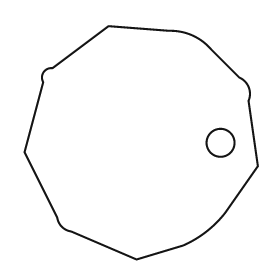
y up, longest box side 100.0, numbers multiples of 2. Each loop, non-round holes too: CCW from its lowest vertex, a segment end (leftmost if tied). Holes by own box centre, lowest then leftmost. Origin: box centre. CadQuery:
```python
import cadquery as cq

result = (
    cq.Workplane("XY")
    .moveTo(-2.0, -50.0)
    .lineTo(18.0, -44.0)
    .threePointArc((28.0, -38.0), (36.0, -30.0))
    .lineTo(50.0, -10.0)
    .lineTo(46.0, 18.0)
    .threePointArc((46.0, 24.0), (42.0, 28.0))
    .lineTo(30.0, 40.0)
    .threePointArc((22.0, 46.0), (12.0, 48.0))
    .lineTo(-14.0, 50.0)
    .lineTo(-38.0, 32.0)
    .threePointArc((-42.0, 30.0), (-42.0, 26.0))
    .lineTo(-50.0, -4.0)
    .lineTo(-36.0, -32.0)
    .threePointArc((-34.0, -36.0), (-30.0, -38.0))
    .close()
    .moveTo(34.0, 0.0)
    .circle(6.0)
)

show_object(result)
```